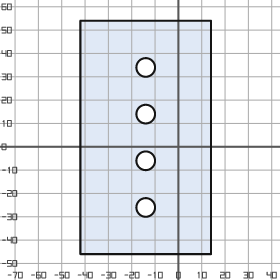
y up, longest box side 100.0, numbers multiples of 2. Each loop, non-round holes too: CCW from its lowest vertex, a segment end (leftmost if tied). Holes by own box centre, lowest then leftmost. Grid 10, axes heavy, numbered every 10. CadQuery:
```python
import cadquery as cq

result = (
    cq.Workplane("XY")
    .moveTo(-42.0, -46.0)
    .lineTo(14.0, -46.0)
    .lineTo(14.0, 54.0)
    .lineTo(-42.0, 54.0)
    .close()
    .moveTo(-14.0, -26.0)
    .circle(4.0)
    .moveTo(-14.0, -6.0)
    .circle(4.0)
    .moveTo(-14.0, 14.0)
    .circle(4.0)
    .moveTo(-14.0, 34.0)
    .circle(4.0)
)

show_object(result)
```